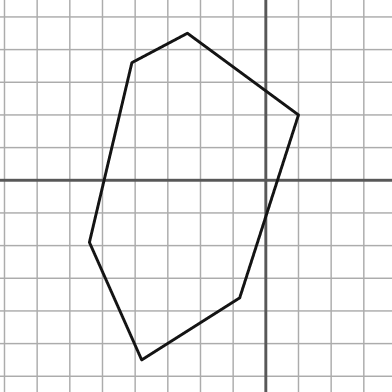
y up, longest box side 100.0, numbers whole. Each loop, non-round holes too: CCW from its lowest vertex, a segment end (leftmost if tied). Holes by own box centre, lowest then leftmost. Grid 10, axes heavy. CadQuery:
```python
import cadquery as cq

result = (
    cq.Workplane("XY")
    .moveTo(-38.0, -55.0)
    .lineTo(-8.0, -36.0)
    .lineTo(10.0, 20.0)
    .lineTo(-24.0, 45.0)
    .lineTo(-41.0, 36.0)
    .lineTo(-54.0, -19.0)
    .close()
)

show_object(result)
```